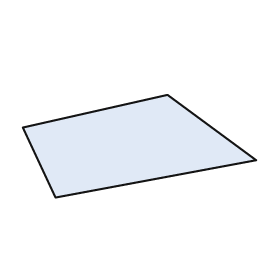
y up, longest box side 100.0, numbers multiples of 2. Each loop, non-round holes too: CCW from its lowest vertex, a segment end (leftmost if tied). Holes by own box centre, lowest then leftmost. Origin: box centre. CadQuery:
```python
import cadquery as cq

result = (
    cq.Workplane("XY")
    .moveTo(-36.0, -22.0)
    .lineTo(50.0, -6.0)
    .lineTo(12.0, 22.0)
    .lineTo(-50.0, 8.0)
    .close()
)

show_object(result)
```